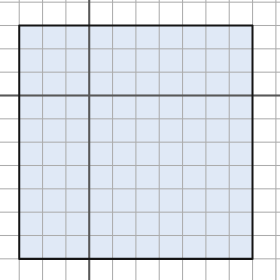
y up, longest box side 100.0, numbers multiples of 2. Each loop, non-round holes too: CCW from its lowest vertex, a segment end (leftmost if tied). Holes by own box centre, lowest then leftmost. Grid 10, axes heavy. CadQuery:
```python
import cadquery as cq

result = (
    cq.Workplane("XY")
    .moveTo(-30.0, -70.0)
    .lineTo(70.0, -70.0)
    .lineTo(70.0, 30.0)
    .lineTo(-30.0, 30.0)
    .close()
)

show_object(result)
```